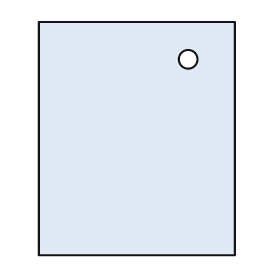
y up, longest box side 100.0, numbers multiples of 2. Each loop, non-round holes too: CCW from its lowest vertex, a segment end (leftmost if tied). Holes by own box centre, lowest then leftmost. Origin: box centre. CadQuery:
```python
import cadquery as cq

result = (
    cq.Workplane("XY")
    .moveTo(-42.0, -50.0)
    .lineTo(42.0, -50.0)
    .lineTo(42.0, 50.0)
    .lineTo(-42.0, 50.0)
    .close()
    .moveTo(22.0, 34.0)
    .circle(4.0)
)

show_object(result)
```